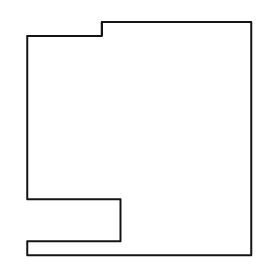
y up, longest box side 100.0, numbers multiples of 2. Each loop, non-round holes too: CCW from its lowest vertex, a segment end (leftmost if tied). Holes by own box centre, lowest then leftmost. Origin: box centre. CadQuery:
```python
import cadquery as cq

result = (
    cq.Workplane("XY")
    .moveTo(-48.0, -50.0)
    .lineTo(48.0, -50.0)
    .lineTo(48.0, 50.0)
    .lineTo(-16.0, 50.0)
    .lineTo(-16.0, 44.0)
    .lineTo(-48.0, 44.0)
    .lineTo(-48.0, -26.0)
    .lineTo(-8.0, -26.0)
    .lineTo(-8.0, -44.0)
    .lineTo(-48.0, -44.0)
    .close()
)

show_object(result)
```